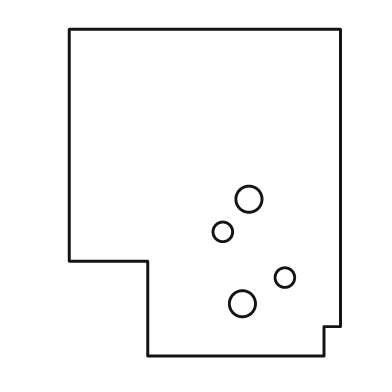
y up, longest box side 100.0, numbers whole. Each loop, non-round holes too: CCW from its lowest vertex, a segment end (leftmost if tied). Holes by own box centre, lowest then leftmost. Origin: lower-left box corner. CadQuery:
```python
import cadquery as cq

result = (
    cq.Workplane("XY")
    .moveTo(24.0, 0.0)
    .lineTo(78.0, 0.0)
    .lineTo(78.0, 9.0)
    .lineTo(83.0, 9.0)
    .lineTo(83.0, 100.0)
    .lineTo(0.0, 100.0)
    .lineTo(0.0, 29.0)
    .lineTo(24.0, 29.0)
    .close()
    .moveTo(53.0, 16.0)
    .circle(4.0)
    .moveTo(66.0, 24.0)
    .circle(3.0)
    .moveTo(47.0, 38.0)
    .circle(3.0)
    .moveTo(55.0, 48.0)
    .circle(4.0)
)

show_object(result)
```